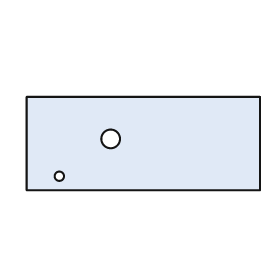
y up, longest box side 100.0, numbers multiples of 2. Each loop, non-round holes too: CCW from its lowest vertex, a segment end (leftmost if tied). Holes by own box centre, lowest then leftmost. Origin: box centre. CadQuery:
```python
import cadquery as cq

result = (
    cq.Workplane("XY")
    .moveTo(-50.0, -20.0)
    .lineTo(50.0, -20.0)
    .lineTo(50.0, 20.0)
    .lineTo(-50.0, 20.0)
    .close()
    .moveTo(-36.0, -14.0)
    .circle(2.0)
    .moveTo(-14.0, 2.0)
    .circle(4.0)
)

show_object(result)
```